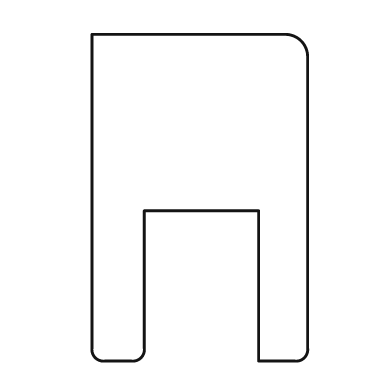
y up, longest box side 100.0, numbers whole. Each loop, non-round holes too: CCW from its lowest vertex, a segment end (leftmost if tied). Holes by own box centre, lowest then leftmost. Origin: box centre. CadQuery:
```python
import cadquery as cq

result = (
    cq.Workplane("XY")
    .moveTo(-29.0, -50.0)
    .lineTo(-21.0, -50.0)
    .threePointArc((-18.0, -49.0), (-17.0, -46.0))
    .lineTo(-17.0, -4.0)
    .lineTo(18.0, -4.0)
    .lineTo(18.0, -50.0)
    .lineTo(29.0, -50.0)
    .threePointArc((32.0, -49.0), (33.0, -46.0))
    .lineTo(33.0, 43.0)
    .threePointArc((31.0, 48.0), (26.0, 50.0))
    .lineTo(-33.0, 50.0)
    .lineTo(-33.0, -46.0)
    .threePointArc((-32.0, -49.0), (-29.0, -50.0))
    .close()
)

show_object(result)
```